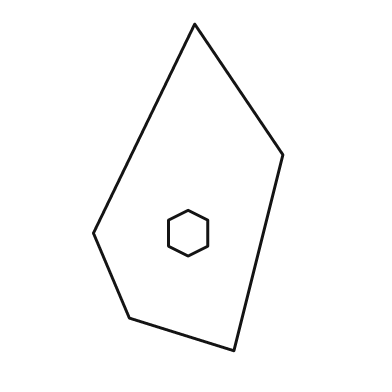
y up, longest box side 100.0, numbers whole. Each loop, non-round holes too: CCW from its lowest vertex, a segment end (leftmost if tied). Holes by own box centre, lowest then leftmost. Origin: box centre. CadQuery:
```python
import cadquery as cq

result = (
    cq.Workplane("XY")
    .moveTo(14.0, -50.0)
    .lineTo(29.0, 10.0)
    .lineTo(2.0, 50.0)
    .lineTo(-29.0, -14.0)
    .lineTo(-18.0, -40.0)
    .close()
    .moveTo(0.0, -21.0)
    .lineTo(6.0, -18.0)
    .lineTo(6.0, -10.0)
    .lineTo(0.0, -7.0)
    .lineTo(-6.0, -10.0)
    .lineTo(-6.0, -18.0)
    .close()
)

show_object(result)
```